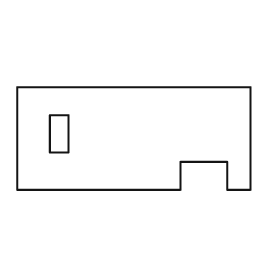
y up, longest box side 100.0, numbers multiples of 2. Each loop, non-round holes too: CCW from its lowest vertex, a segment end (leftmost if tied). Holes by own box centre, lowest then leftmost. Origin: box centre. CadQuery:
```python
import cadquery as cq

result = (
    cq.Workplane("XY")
    .moveTo(-50.0, -22.0)
    .lineTo(20.0, -22.0)
    .lineTo(20.0, -10.0)
    .lineTo(40.0, -10.0)
    .lineTo(40.0, -22.0)
    .lineTo(50.0, -22.0)
    .lineTo(50.0, 22.0)
    .lineTo(-50.0, 22.0)
    .close()
    .moveTo(-36.0, -6.0)
    .lineTo(-28.0, -6.0)
    .lineTo(-28.0, 10.0)
    .lineTo(-36.0, 10.0)
    .close()
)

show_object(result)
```